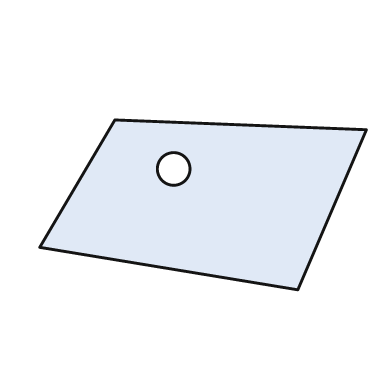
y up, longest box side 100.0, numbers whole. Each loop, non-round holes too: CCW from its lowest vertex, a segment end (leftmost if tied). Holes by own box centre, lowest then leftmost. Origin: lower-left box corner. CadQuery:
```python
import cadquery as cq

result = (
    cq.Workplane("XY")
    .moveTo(79.0, 0.0)
    .lineTo(100.0, 49.0)
    .lineTo(23.0, 52.0)
    .lineTo(0.0, 13.0)
    .close()
    .moveTo(41.0, 37.0)
    .circle(5.0)
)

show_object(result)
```